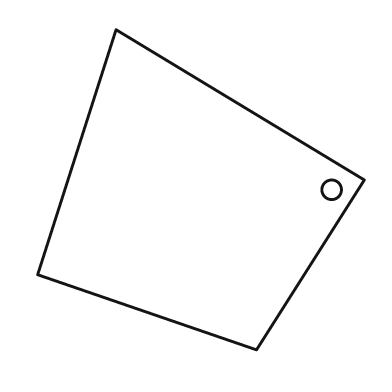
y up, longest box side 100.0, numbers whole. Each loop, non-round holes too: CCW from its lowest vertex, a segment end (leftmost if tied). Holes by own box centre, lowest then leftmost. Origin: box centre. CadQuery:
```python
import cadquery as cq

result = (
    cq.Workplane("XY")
    .moveTo(17.0, -49.0)
    .lineTo(50.0, 3.0)
    .lineTo(-26.0, 49.0)
    .lineTo(-50.0, -26.0)
    .close()
    .moveTo(40.0, 0.0)
    .circle(3.0)
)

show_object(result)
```